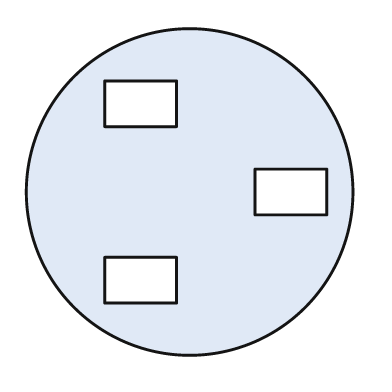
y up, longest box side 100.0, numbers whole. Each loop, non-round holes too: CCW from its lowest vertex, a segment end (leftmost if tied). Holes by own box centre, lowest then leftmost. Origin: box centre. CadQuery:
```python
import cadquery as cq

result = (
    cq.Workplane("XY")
    .moveTo(0.0, 0.0)
    .circle(50.0)
    .moveTo(-26.0, -34.0)
    .lineTo(-4.0, -34.0)
    .lineTo(-4.0, -20.0)
    .lineTo(-26.0, -20.0)
    .close()
    .moveTo(20.0, -7.0)
    .lineTo(42.0, -7.0)
    .lineTo(42.0, 7.0)
    .lineTo(20.0, 7.0)
    .close()
    .moveTo(-26.0, 20.0)
    .lineTo(-4.0, 20.0)
    .lineTo(-4.0, 34.0)
    .lineTo(-26.0, 34.0)
    .close()
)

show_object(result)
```